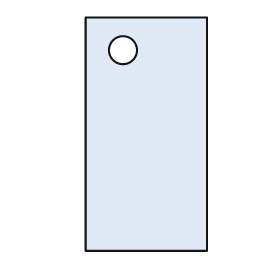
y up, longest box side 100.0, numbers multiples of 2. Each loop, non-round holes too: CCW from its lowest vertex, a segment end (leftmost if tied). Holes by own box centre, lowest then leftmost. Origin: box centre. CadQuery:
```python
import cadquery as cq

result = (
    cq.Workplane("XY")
    .moveTo(-26.0, -50.0)
    .lineTo(26.0, -50.0)
    .lineTo(26.0, 50.0)
    .lineTo(-26.0, 50.0)
    .close()
    .moveTo(-10.0, 36.0)
    .circle(6.0)
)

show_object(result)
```